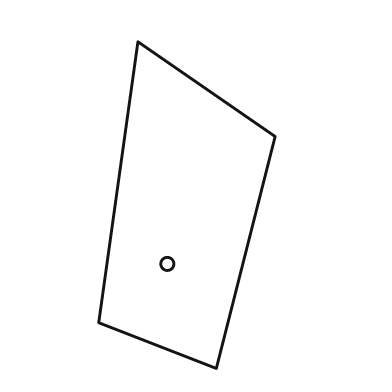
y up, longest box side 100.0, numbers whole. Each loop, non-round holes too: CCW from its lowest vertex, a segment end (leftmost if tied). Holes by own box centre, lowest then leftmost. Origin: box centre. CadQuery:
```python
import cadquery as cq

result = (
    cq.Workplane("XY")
    .moveTo(9.0, -50.0)
    .lineTo(27.0, 21.0)
    .lineTo(-15.0, 50.0)
    .lineTo(-27.0, -36.0)
    .close()
    .moveTo(-6.0, -18.0)
    .circle(2.0)
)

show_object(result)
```